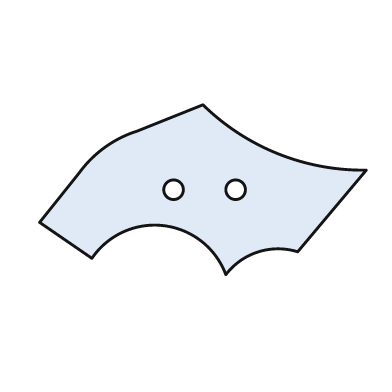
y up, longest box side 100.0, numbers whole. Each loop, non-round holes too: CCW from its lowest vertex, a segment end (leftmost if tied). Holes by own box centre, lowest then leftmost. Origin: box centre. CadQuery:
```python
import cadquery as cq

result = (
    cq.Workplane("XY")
    .moveTo(7.0, -26.0)
    .threePointArc((17.0, -19.0), (29.0, -19.0))
    .lineTo(50.0, 6.0)
    .threePointArc((23.0, 11.0), (0.0, 26.0))
    .lineTo(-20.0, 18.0)
    .threePointArc((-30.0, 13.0), (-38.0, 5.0))
    .lineTo(-50.0, -10.0)
    .lineTo(-34.0, -21.0)
    .threePointArc((-12.0, -11.0), (7.0, -26.0))
    .close()
    .moveTo(-9.0, 0.0)
    .circle(3.0)
    .moveTo(10.0, 0.0)
    .circle(3.0)
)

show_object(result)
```